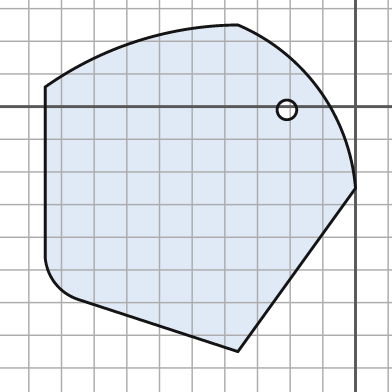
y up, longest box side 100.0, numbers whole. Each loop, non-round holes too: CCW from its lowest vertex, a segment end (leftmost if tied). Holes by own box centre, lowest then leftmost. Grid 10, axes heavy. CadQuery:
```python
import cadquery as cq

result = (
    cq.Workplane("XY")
    .moveTo(-36.0, -75.0)
    .lineTo(0.0, -25.0)
    .threePointArc((-11.0, 5.0), (-36.0, 25.0))
    .threePointArc((-67.0, 20.0), (-95.0, 6.0))
    .lineTo(-95.0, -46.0)
    .threePointArc((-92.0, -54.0), (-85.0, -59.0))
    .close()
    .moveTo(-21.0, -1.0)
    .circle(3.0)
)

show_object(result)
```